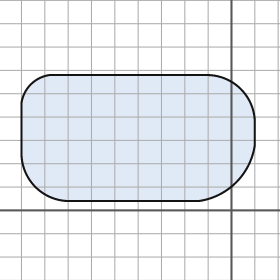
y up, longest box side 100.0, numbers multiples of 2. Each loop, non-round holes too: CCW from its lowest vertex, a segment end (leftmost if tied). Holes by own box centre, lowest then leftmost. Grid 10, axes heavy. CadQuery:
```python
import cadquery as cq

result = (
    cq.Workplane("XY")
    .moveTo(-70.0, 4.0)
    .lineTo(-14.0, 4.0)
    .threePointArc((2.0, 12.0), (10.0, 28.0))
    .lineTo(10.0, 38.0)
    .threePointArc((4.0, 52.0), (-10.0, 58.0))
    .lineTo(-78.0, 58.0)
    .threePointArc((-86.0, 54.0), (-90.0, 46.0))
    .lineTo(-90.0, 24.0)
    .threePointArc((-84.0, 10.0), (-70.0, 4.0))
    .close()
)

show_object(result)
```